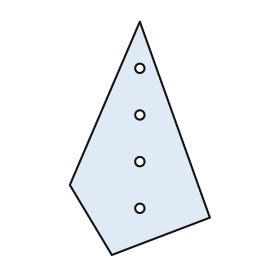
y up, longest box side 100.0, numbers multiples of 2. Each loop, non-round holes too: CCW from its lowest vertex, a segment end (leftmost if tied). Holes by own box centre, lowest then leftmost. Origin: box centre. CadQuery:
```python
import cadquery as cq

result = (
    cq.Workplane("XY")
    .moveTo(-12.0, -50.0)
    .lineTo(30.0, -34.0)
    .lineTo(0.0, 50.0)
    .lineTo(-30.0, -20.0)
    .close()
    .moveTo(0.0, -30.0)
    .circle(2.0)
    .moveTo(0.0, -10.0)
    .circle(2.0)
    .moveTo(0.0, 10.0)
    .circle(2.0)
    .moveTo(0.0, 30.0)
    .circle(2.0)
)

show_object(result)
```